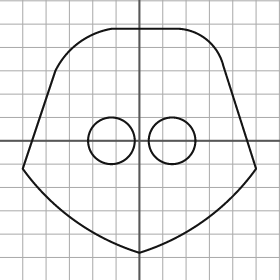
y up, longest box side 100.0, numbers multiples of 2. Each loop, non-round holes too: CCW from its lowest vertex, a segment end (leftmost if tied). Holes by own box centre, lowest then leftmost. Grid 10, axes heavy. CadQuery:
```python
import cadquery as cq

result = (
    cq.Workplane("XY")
    .moveTo(0.0, -48.0)
    .threePointArc((28.0, -34.0), (50.0, -12.0))
    .lineTo(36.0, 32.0)
    .threePointArc((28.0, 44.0), (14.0, 48.0))
    .lineTo(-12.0, 48.0)
    .threePointArc((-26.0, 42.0), (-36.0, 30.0))
    .lineTo(-50.0, -12.0)
    .threePointArc((-28.0, -34.0), (0.0, -48.0))
    .close()
    .moveTo(-12.0, 0.0)
    .circle(10.0)
    .moveTo(14.0, 0.0)
    .circle(10.0)
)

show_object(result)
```